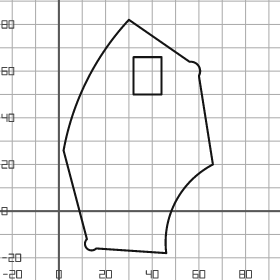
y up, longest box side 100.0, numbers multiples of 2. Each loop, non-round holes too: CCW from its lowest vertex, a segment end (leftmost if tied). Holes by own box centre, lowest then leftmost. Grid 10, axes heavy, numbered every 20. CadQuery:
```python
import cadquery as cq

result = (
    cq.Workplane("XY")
    .moveTo(46.0, -18.0)
    .threePointArc((50.0, 4.0), (66.0, 20.0))
    .lineTo(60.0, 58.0)
    .threePointArc((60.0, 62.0), (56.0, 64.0))
    .lineTo(30.0, 82.0)
    .threePointArc((12.0, 56.0), (2.0, 26.0))
    .lineTo(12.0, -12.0)
    .threePointArc((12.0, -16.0), (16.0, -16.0))
    .close()
    .moveTo(32.0, 50.0)
    .lineTo(44.0, 50.0)
    .lineTo(44.0, 66.0)
    .lineTo(32.0, 66.0)
    .close()
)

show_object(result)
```